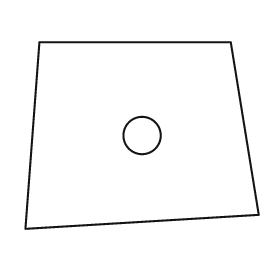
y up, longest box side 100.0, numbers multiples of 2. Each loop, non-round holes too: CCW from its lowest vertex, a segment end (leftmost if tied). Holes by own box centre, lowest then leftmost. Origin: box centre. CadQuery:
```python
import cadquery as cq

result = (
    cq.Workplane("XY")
    .moveTo(-50.0, -40.0)
    .lineTo(50.0, -34.0)
    .lineTo(38.0, 40.0)
    .lineTo(-44.0, 40.0)
    .close()
    .moveTo(0.0, 0.0)
    .circle(8.0)
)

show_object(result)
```